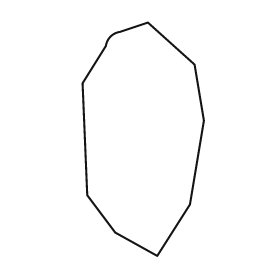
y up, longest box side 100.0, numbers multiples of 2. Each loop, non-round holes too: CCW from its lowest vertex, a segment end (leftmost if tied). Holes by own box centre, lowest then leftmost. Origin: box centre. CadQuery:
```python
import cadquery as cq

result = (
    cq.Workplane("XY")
    .moveTo(6.0, -50.0)
    .lineTo(20.0, -28.0)
    .lineTo(26.0, 8.0)
    .lineTo(22.0, 32.0)
    .lineTo(2.0, 50.0)
    .lineTo(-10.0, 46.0)
    .threePointArc((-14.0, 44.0), (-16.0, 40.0))
    .lineTo(-26.0, 24.0)
    .lineTo(-24.0, -24.0)
    .lineTo(-12.0, -40.0)
    .close()
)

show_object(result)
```